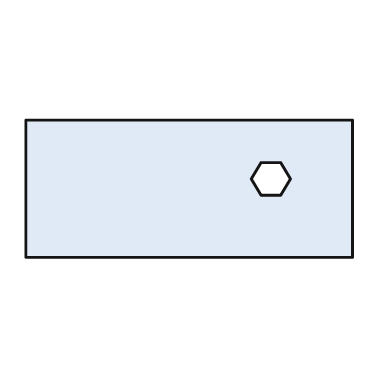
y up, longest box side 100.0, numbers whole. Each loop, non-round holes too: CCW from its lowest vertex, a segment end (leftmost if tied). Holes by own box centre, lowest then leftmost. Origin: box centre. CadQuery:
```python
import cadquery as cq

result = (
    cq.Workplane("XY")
    .moveTo(-50.0, -21.0)
    .lineTo(50.0, -21.0)
    .lineTo(50.0, 21.0)
    .lineTo(-50.0, 21.0)
    .close()
    .moveTo(22.0, -2.0)
    .lineTo(28.0, -2.0)
    .lineTo(31.0, 3.0)
    .lineTo(28.0, 8.0)
    .lineTo(22.0, 8.0)
    .lineTo(19.0, 3.0)
    .close()
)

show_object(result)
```